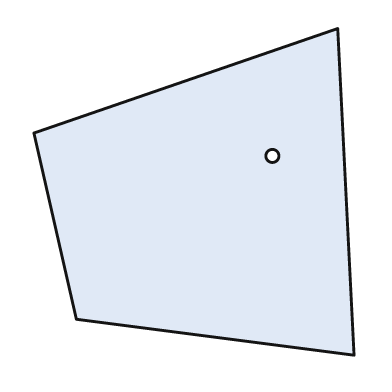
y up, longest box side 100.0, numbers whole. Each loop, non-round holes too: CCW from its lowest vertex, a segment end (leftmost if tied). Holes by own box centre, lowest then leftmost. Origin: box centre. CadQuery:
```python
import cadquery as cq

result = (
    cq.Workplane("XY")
    .moveTo(49.0, -50.0)
    .lineTo(44.0, 50.0)
    .lineTo(-49.0, 18.0)
    .lineTo(-36.0, -39.0)
    .close()
    .moveTo(24.0, 11.0)
    .circle(2.0)
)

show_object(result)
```